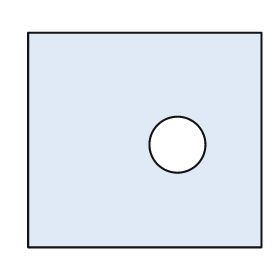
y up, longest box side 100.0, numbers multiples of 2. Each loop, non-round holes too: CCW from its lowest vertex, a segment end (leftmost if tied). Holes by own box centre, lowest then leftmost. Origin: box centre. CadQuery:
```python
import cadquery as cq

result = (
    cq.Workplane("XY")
    .moveTo(-50.0, -46.0)
    .lineTo(50.0, -46.0)
    .lineTo(50.0, 46.0)
    .lineTo(-50.0, 46.0)
    .close()
    .moveTo(14.0, -2.0)
    .circle(12.0)
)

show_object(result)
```